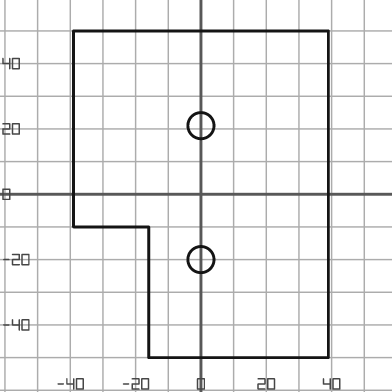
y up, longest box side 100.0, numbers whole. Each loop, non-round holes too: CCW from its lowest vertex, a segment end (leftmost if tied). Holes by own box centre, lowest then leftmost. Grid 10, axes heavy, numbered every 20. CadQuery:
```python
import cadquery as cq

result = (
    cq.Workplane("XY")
    .moveTo(-16.0, -50.0)
    .lineTo(39.0, -50.0)
    .lineTo(39.0, 50.0)
    .lineTo(-39.0, 50.0)
    .lineTo(-39.0, -10.0)
    .lineTo(-16.0, -10.0)
    .close()
    .moveTo(0.0, -20.0)
    .circle(4.0)
    .moveTo(0.0, 21.0)
    .circle(4.0)
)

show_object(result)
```